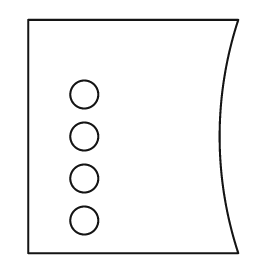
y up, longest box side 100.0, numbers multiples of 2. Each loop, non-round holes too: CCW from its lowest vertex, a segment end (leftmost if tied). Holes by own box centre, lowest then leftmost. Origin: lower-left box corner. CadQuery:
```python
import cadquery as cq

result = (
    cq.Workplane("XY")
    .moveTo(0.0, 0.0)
    .lineTo(90.0, 0.0)
    .threePointArc((82.0, 50.0), (90.0, 100.0))
    .lineTo(0.0, 100.0)
    .close()
    .moveTo(24.0, 14.0)
    .circle(6.0)
    .moveTo(24.0, 32.0)
    .circle(6.0)
    .moveTo(24.0, 50.0)
    .circle(6.0)
    .moveTo(24.0, 68.0)
    .circle(6.0)
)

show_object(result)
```